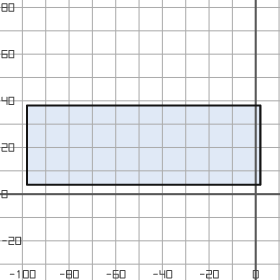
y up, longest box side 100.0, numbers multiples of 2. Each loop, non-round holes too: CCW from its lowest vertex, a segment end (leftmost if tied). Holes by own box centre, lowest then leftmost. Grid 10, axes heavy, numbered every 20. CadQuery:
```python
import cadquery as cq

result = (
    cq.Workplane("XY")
    .moveTo(-98.0, 4.0)
    .lineTo(2.0, 4.0)
    .lineTo(2.0, 38.0)
    .lineTo(-98.0, 38.0)
    .close()
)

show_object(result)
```